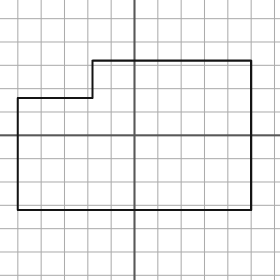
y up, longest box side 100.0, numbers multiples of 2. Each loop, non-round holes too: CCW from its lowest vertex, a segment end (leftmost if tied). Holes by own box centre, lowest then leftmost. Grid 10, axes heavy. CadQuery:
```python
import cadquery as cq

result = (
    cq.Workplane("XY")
    .moveTo(-50.0, -32.0)
    .lineTo(50.0, -32.0)
    .lineTo(50.0, 32.0)
    .lineTo(-18.0, 32.0)
    .lineTo(-18.0, 16.0)
    .lineTo(-50.0, 16.0)
    .close()
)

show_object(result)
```